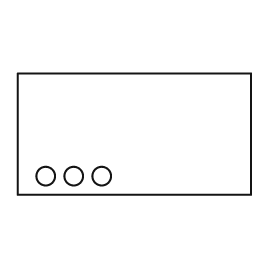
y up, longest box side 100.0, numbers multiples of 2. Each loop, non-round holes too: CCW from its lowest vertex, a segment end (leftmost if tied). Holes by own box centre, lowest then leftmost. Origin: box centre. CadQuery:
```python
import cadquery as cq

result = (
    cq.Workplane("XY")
    .moveTo(-50.0, -26.0)
    .lineTo(50.0, -26.0)
    .lineTo(50.0, 26.0)
    .lineTo(-50.0, 26.0)
    .close()
    .moveTo(-38.0, -18.0)
    .circle(4.0)
    .moveTo(-26.0, -18.0)
    .circle(4.0)
    .moveTo(-14.0, -18.0)
    .circle(4.0)
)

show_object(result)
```